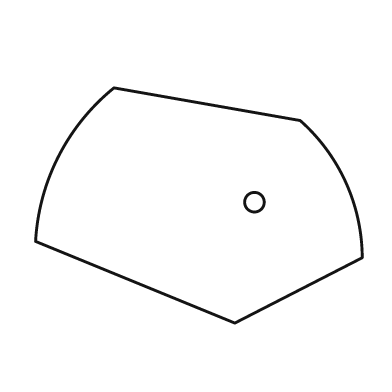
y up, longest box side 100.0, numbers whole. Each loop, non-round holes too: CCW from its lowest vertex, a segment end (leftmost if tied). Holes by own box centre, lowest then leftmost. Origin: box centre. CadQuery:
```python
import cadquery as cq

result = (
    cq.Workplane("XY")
    .moveTo(11.0, -36.0)
    .lineTo(50.0, -16.0)
    .threePointArc((45.0, 7.0), (31.0, 26.0))
    .lineTo(-26.0, 36.0)
    .threePointArc((-43.0, 15.0), (-50.0, -11.0))
    .close()
    .moveTo(17.0, 1.0)
    .circle(3.0)
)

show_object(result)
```